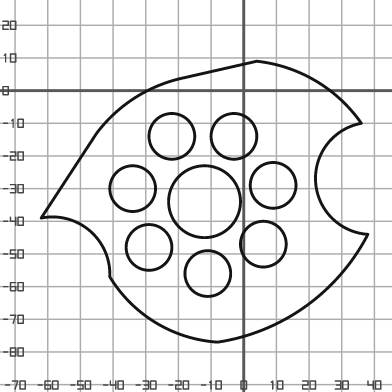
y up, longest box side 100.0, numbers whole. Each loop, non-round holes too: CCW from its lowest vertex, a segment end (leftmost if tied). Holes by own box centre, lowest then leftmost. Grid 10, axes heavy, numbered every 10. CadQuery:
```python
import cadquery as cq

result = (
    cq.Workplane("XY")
    .moveTo(-8.0, -77.0)
    .threePointArc((19.0, -66.0), (38.0, -44.0))
    .threePointArc((22.0, -28.0), (36.0, -10.0))
    .threePointArc((22.0, 3.0), (4.0, 9.0))
    .lineTo(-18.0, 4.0)
    .threePointArc((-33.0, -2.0), (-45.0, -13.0))
    .lineTo(-62.0, -39.0)
    .threePointArc((-47.0, -43.0), (-41.0, -57.0))
    .threePointArc((-27.0, -71.0), (-8.0, -77.0))
    .close()
    .moveTo(-11.0, -56.0)
    .circle(7.0)
    .moveTo(-29.0, -48.0)
    .circle(7.0)
    .moveTo(6.0, -47.0)
    .circle(7.0)
    .moveTo(-12.0, -34.0)
    .circle(11.0)
    .moveTo(-34.0, -30.0)
    .circle(7.0)
    .moveTo(9.0, -29.0)
    .circle(7.0)
    .moveTo(-22.0, -14.0)
    .circle(7.0)
    .moveTo(-3.0, -14.0)
    .circle(7.0)
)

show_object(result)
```